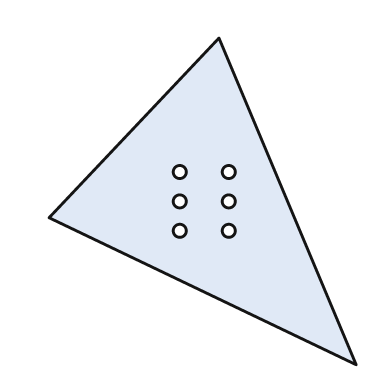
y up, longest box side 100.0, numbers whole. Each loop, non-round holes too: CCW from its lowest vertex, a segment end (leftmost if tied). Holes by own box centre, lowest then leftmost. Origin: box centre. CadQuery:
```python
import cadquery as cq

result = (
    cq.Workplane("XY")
    .moveTo(47.0, -50.0)
    .lineTo(5.0, 50.0)
    .lineTo(-47.0, -5.0)
    .close()
    .moveTo(-7.0, -9.0)
    .circle(2.0)
    .moveTo(8.0, -9.0)
    .circle(2.0)
    .moveTo(-7.0, 0.0)
    .circle(2.0)
    .moveTo(8.0, 0.0)
    .circle(2.0)
    .moveTo(-7.0, 9.0)
    .circle(2.0)
    .moveTo(8.0, 9.0)
    .circle(2.0)
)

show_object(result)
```